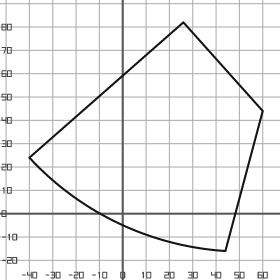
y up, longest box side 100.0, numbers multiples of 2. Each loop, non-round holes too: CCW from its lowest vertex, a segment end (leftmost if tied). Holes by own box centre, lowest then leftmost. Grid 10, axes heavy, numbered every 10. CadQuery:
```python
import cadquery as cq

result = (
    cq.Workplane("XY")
    .moveTo(44.0, -16.0)
    .lineTo(60.0, 44.0)
    .lineTo(26.0, 82.0)
    .lineTo(-40.0, 24.0)
    .threePointArc((-2.0, -4.0), (44.0, -16.0))
    .close()
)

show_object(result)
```